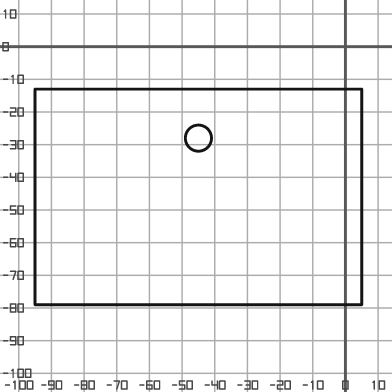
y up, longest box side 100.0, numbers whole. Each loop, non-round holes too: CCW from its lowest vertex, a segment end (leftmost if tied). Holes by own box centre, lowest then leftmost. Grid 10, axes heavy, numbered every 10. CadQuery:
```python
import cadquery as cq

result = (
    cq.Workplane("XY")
    .moveTo(-95.0, -79.0)
    .lineTo(5.0, -79.0)
    .lineTo(5.0, -13.0)
    .lineTo(-95.0, -13.0)
    .close()
    .moveTo(-45.0, -28.0)
    .circle(4.0)
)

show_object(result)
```